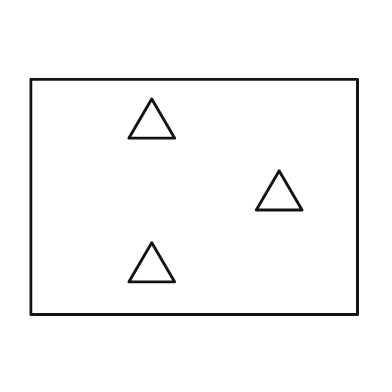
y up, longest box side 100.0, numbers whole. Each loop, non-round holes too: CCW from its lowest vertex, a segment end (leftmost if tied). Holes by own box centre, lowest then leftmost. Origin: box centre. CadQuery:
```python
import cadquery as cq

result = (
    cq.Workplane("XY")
    .moveTo(-50.0, -36.0)
    .lineTo(50.0, -36.0)
    .lineTo(50.0, 36.0)
    .lineTo(-50.0, 36.0)
    .close()
    .moveTo(-20.0, -26.0)
    .lineTo(-6.0, -26.0)
    .lineTo(-13.0, -14.0)
    .close()
    .moveTo(19.0, -4.0)
    .lineTo(33.0, -4.0)
    .lineTo(26.0, 8.0)
    .close()
    .moveTo(-20.0, 18.0)
    .lineTo(-6.0, 18.0)
    .lineTo(-13.0, 30.0)
    .close()
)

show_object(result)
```